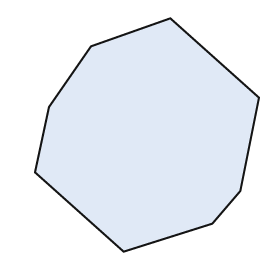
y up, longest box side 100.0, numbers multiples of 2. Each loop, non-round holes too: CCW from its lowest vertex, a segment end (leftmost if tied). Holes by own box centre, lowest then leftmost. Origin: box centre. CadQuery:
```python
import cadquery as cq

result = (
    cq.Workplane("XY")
    .moveTo(-10.0, -50.0)
    .lineTo(28.0, -38.0)
    .lineTo(40.0, -24.0)
    .lineTo(48.0, 16.0)
    .lineTo(10.0, 50.0)
    .lineTo(-24.0, 38.0)
    .lineTo(-42.0, 12.0)
    .lineTo(-48.0, -16.0)
    .close()
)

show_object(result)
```